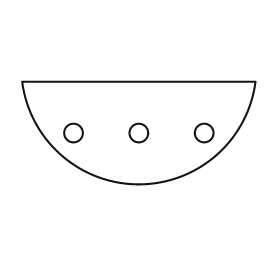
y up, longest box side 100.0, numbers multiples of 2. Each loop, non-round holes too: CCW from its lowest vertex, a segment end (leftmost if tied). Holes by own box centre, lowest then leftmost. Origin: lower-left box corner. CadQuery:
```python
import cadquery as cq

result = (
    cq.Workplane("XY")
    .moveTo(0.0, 44.0)
    .threePointArc((50.0, 0.0), (100.0, 44.0))
    .close()
    .moveTo(22.0, 22.0)
    .circle(4.0)
    .moveTo(50.0, 22.0)
    .circle(4.0)
    .moveTo(78.0, 22.0)
    .circle(4.0)
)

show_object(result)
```